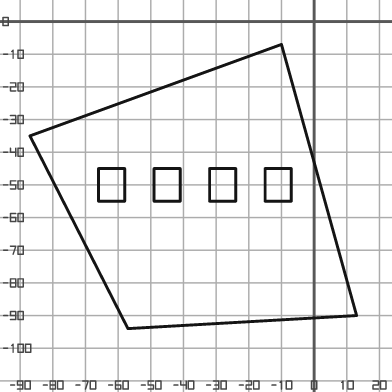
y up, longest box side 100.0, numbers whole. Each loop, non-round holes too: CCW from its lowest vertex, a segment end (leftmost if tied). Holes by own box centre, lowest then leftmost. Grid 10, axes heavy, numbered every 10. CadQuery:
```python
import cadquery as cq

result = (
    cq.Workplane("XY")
    .moveTo(-57.0, -94.0)
    .lineTo(13.0, -90.0)
    .lineTo(-10.0, -7.0)
    .lineTo(-87.0, -35.0)
    .close()
    .moveTo(-66.0, -55.0)
    .lineTo(-58.0, -55.0)
    .lineTo(-58.0, -45.0)
    .lineTo(-66.0, -45.0)
    .close()
    .moveTo(-49.0, -55.0)
    .lineTo(-41.0, -55.0)
    .lineTo(-41.0, -45.0)
    .lineTo(-49.0, -45.0)
    .close()
    .moveTo(-32.0, -55.0)
    .lineTo(-24.0, -55.0)
    .lineTo(-24.0, -45.0)
    .lineTo(-32.0, -45.0)
    .close()
    .moveTo(-15.0, -55.0)
    .lineTo(-7.0, -55.0)
    .lineTo(-7.0, -45.0)
    .lineTo(-15.0, -45.0)
    .close()
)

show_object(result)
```